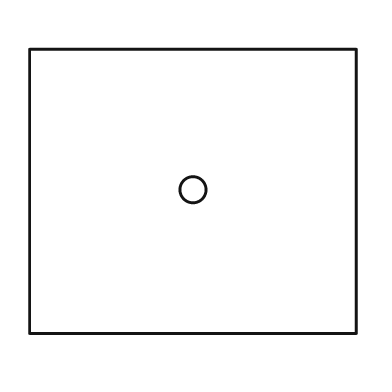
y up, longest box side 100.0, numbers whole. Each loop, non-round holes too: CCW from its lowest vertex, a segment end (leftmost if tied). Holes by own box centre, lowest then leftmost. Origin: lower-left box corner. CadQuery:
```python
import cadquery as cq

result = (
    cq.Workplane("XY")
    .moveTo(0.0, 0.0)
    .lineTo(100.0, 0.0)
    .lineTo(100.0, 87.0)
    .lineTo(0.0, 87.0)
    .close()
    .moveTo(50.0, 44.0)
    .circle(4.0)
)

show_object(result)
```